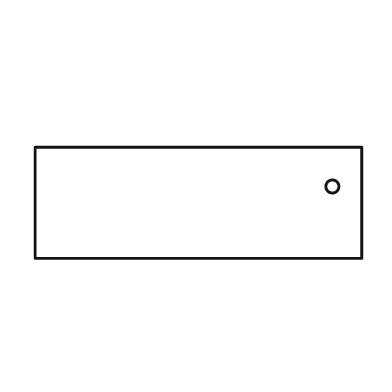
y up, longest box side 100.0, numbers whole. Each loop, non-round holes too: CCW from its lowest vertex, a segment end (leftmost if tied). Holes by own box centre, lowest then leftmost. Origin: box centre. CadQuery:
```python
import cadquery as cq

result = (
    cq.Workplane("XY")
    .moveTo(-50.0, -17.0)
    .lineTo(50.0, -17.0)
    .lineTo(50.0, 17.0)
    .lineTo(-50.0, 17.0)
    .close()
    .moveTo(41.0, 5.0)
    .circle(2.0)
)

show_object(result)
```